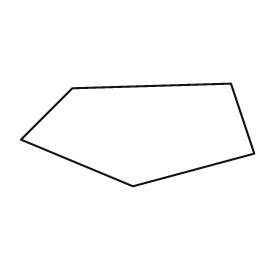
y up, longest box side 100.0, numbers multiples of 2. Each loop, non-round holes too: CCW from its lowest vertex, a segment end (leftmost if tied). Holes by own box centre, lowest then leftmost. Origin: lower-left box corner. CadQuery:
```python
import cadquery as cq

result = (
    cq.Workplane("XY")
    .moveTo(48.0, 0.0)
    .lineTo(100.0, 14.0)
    .lineTo(90.0, 44.0)
    .lineTo(22.0, 42.0)
    .lineTo(0.0, 20.0)
    .close()
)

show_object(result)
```